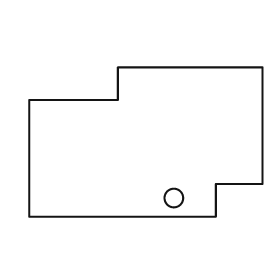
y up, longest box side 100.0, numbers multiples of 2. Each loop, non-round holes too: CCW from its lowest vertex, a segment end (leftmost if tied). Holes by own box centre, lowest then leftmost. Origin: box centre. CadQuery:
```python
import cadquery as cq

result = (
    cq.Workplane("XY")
    .moveTo(-50.0, -32.0)
    .lineTo(30.0, -32.0)
    .lineTo(30.0, -18.0)
    .lineTo(50.0, -18.0)
    .lineTo(50.0, 32.0)
    .lineTo(-12.0, 32.0)
    .lineTo(-12.0, 18.0)
    .lineTo(-50.0, 18.0)
    .close()
    .moveTo(12.0, -24.0)
    .circle(4.0)
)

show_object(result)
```